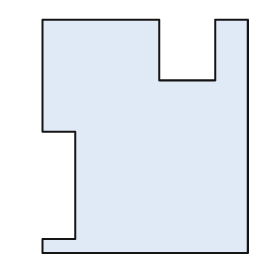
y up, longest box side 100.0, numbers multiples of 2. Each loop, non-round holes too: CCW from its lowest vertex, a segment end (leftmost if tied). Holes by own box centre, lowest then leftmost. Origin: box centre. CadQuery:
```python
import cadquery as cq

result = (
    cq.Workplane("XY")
    .moveTo(-44.0, -50.0)
    .lineTo(44.0, -50.0)
    .lineTo(44.0, 50.0)
    .lineTo(30.0, 50.0)
    .lineTo(30.0, 24.0)
    .lineTo(6.0, 24.0)
    .lineTo(6.0, 50.0)
    .lineTo(-44.0, 50.0)
    .lineTo(-44.0, 2.0)
    .lineTo(-30.0, 2.0)
    .lineTo(-30.0, -44.0)
    .lineTo(-44.0, -44.0)
    .close()
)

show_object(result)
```